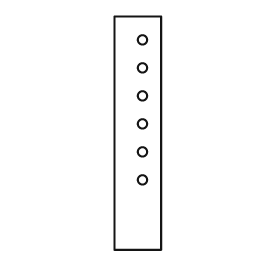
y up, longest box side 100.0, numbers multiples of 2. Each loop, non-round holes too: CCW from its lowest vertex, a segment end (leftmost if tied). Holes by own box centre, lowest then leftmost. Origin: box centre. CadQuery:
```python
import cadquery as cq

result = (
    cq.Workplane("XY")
    .moveTo(-10.0, -50.0)
    .lineTo(10.0, -50.0)
    .lineTo(10.0, 50.0)
    .lineTo(-10.0, 50.0)
    .close()
    .moveTo(2.0, -20.0)
    .circle(2.0)
    .moveTo(2.0, -8.0)
    .circle(2.0)
    .moveTo(2.0, 4.0)
    .circle(2.0)
    .moveTo(2.0, 16.0)
    .circle(2.0)
    .moveTo(2.0, 28.0)
    .circle(2.0)
    .moveTo(2.0, 40.0)
    .circle(2.0)
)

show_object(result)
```